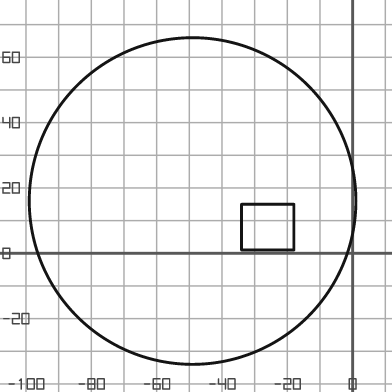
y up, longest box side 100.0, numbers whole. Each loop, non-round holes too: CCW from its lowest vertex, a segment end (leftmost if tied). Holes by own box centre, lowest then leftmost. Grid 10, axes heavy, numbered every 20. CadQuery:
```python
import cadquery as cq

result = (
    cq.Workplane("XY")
    .moveTo(-49.0, 16.0)
    .circle(50.0)
    .moveTo(-34.0, 1.0)
    .lineTo(-18.0, 1.0)
    .lineTo(-18.0, 15.0)
    .lineTo(-34.0, 15.0)
    .close()
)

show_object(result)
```